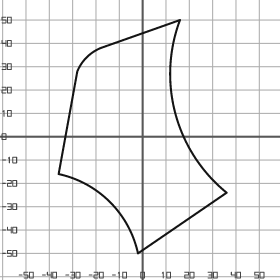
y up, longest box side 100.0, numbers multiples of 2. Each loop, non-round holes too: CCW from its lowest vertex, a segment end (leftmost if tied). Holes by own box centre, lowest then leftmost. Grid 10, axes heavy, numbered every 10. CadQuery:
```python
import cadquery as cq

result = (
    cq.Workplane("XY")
    .moveTo(-2.0, -50.0)
    .lineTo(36.0, -24.0)
    .threePointArc((14.0, 10.0), (16.0, 50.0))
    .lineTo(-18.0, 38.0)
    .threePointArc((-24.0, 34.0), (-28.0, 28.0))
    .lineTo(-36.0, -16.0)
    .threePointArc((-14.0, -28.0), (-2.0, -50.0))
    .close()
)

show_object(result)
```